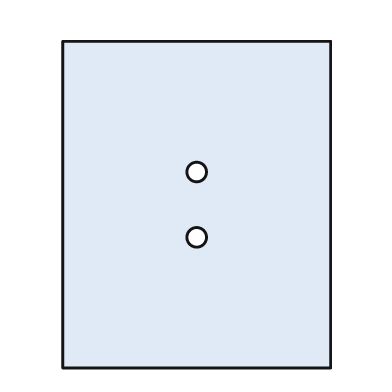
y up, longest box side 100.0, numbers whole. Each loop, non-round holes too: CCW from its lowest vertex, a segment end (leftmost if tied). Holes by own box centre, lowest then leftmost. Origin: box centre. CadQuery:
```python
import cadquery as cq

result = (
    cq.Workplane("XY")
    .moveTo(-41.0, -50.0)
    .lineTo(41.0, -50.0)
    .lineTo(41.0, 50.0)
    .lineTo(-41.0, 50.0)
    .close()
    .moveTo(0.0, -10.0)
    .circle(3.0)
    .moveTo(0.0, 10.0)
    .circle(3.0)
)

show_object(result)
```